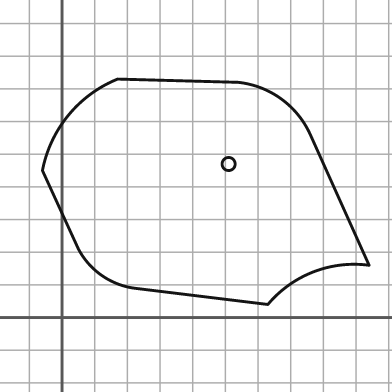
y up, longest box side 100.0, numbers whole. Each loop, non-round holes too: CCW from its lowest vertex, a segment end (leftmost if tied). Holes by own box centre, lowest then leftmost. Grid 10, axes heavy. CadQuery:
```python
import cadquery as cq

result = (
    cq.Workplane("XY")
    .moveTo(63.0, 4.0)
    .threePointArc((77.0, 14.0), (94.0, 16.0))
    .lineTo(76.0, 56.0)
    .threePointArc((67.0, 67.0), (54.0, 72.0))
    .lineTo(17.0, 73.0)
    .threePointArc((2.0, 62.0), (-6.0, 45.0))
    .lineTo(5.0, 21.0)
    .threePointArc((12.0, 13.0), (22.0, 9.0))
    .close()
    .moveTo(51.0, 47.0)
    .circle(2.0)
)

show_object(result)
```